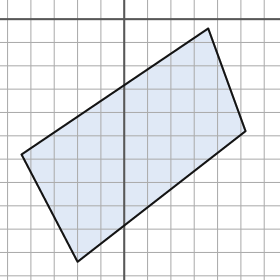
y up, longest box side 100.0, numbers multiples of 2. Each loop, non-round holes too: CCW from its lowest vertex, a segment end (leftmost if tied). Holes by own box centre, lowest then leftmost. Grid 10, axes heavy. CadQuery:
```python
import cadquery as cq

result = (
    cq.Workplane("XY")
    .moveTo(-20.0, -104.0)
    .lineTo(52.0, -48.0)
    .lineTo(36.0, -4.0)
    .lineTo(-44.0, -58.0)
    .close()
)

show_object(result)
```